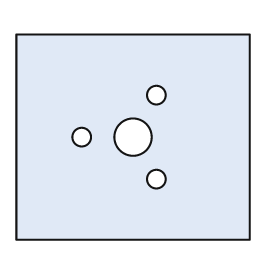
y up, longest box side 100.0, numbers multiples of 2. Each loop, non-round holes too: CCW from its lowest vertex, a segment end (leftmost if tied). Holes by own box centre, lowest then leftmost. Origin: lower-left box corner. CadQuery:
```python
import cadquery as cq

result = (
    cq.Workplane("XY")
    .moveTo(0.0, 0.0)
    .lineTo(100.0, 0.0)
    .lineTo(100.0, 88.0)
    .lineTo(0.0, 88.0)
    .close()
    .moveTo(60.0, 26.0)
    .circle(4.0)
    .moveTo(28.0, 44.0)
    .circle(4.0)
    .moveTo(50.0, 44.0)
    .circle(8.0)
    .moveTo(60.0, 62.0)
    .circle(4.0)
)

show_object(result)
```